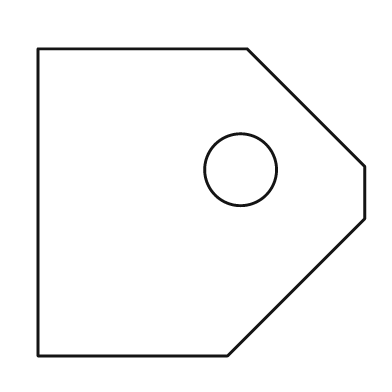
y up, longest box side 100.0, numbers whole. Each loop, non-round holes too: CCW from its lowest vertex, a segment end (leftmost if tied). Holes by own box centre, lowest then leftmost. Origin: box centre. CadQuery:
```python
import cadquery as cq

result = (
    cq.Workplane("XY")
    .moveTo(-50.0, -47.0)
    .lineTo(8.0, -47.0)
    .lineTo(50.0, -5.0)
    .lineTo(50.0, 11.0)
    .lineTo(14.0, 47.0)
    .lineTo(-50.0, 47.0)
    .close()
    .moveTo(12.0, 10.0)
    .circle(11.0)
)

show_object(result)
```